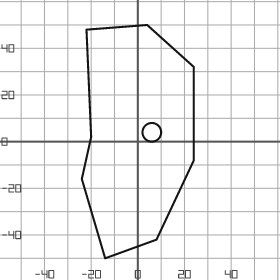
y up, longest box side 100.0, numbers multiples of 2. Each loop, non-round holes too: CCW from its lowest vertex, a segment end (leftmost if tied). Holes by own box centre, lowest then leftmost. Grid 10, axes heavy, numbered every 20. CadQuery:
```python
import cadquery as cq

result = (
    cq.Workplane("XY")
    .moveTo(-14.0, -50.0)
    .lineTo(8.0, -42.0)
    .lineTo(24.0, -8.0)
    .lineTo(24.0, 32.0)
    .lineTo(4.0, 50.0)
    .lineTo(-22.0, 48.0)
    .lineTo(-20.0, 2.0)
    .lineTo(-24.0, -16.0)
    .close()
    .moveTo(6.0, 4.0)
    .circle(4.0)
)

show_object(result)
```